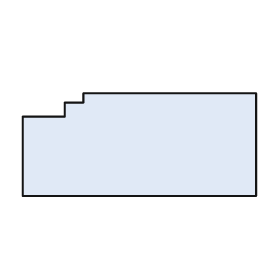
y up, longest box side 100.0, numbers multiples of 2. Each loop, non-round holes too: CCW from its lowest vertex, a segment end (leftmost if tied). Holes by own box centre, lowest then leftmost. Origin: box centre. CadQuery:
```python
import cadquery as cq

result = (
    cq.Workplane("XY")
    .moveTo(-50.0, -22.0)
    .lineTo(50.0, -22.0)
    .lineTo(50.0, 22.0)
    .lineTo(-24.0, 22.0)
    .lineTo(-24.0, 18.0)
    .lineTo(-32.0, 18.0)
    .lineTo(-32.0, 12.0)
    .lineTo(-50.0, 12.0)
    .close()
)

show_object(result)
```